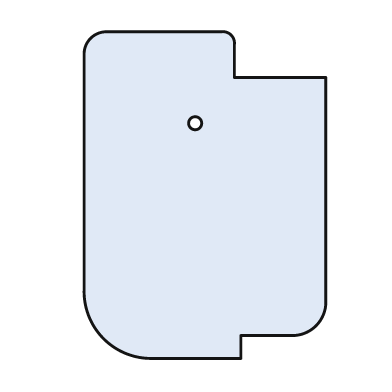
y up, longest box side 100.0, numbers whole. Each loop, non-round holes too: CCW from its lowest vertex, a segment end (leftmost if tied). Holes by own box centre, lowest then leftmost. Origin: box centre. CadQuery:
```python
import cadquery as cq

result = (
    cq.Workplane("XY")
    .moveTo(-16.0, -50.0)
    .lineTo(11.0, -50.0)
    .lineTo(11.0, -43.0)
    .lineTo(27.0, -43.0)
    .threePointArc((34.0, -40.0), (37.0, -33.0))
    .lineTo(37.0, 36.0)
    .lineTo(9.0, 36.0)
    .lineTo(9.0, 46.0)
    .threePointArc((8.0, 49.0), (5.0, 50.0))
    .lineTo(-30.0, 50.0)
    .threePointArc((-35.0, 48.0), (-37.0, 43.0))
    .lineTo(-37.0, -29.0)
    .threePointArc((-31.0, -44.0), (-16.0, -50.0))
    .close()
    .moveTo(-3.0, 22.0)
    .circle(2.0)
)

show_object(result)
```